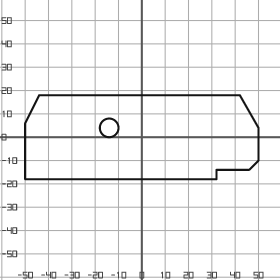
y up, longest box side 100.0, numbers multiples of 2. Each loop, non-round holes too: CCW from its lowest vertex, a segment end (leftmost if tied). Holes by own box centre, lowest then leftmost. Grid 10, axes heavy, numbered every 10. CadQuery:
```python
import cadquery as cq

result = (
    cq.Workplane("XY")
    .moveTo(-50.0, -18.0)
    .lineTo(32.0, -18.0)
    .lineTo(32.0, -14.0)
    .lineTo(46.0, -14.0)
    .lineTo(50.0, -10.0)
    .lineTo(50.0, 4.0)
    .lineTo(42.0, 18.0)
    .lineTo(-44.0, 18.0)
    .lineTo(-50.0, 6.0)
    .close()
    .moveTo(-14.0, 4.0)
    .circle(4.0)
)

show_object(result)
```